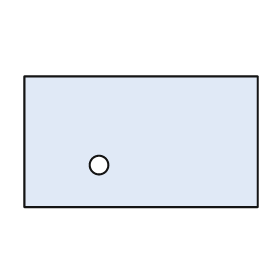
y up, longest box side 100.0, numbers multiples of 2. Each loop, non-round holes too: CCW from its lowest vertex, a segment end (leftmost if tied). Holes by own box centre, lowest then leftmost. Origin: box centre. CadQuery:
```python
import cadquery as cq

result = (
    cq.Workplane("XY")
    .moveTo(-50.0, -28.0)
    .lineTo(50.0, -28.0)
    .lineTo(50.0, 28.0)
    .lineTo(-50.0, 28.0)
    .close()
    .moveTo(-18.0, -10.0)
    .circle(4.0)
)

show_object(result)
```